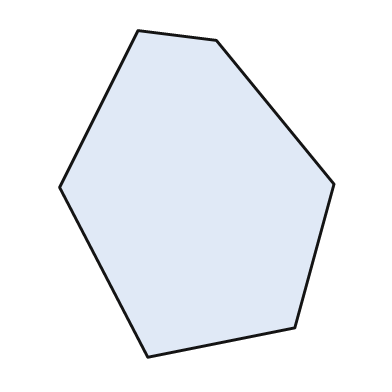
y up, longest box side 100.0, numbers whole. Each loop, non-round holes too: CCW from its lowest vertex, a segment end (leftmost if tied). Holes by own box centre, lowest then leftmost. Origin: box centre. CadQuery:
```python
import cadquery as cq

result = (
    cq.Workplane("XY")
    .moveTo(-15.0, -50.0)
    .lineTo(30.0, -41.0)
    .lineTo(42.0, 3.0)
    .lineTo(6.0, 47.0)
    .lineTo(-18.0, 50.0)
    .lineTo(-42.0, 2.0)
    .close()
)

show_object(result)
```